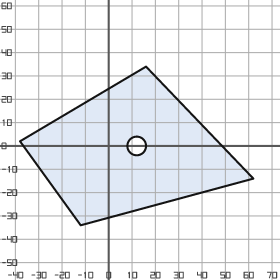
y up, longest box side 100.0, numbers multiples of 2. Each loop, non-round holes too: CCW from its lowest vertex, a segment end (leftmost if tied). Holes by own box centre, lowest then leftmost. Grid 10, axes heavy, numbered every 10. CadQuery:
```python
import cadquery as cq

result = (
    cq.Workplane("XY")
    .moveTo(-12.0, -34.0)
    .lineTo(62.0, -14.0)
    .lineTo(16.0, 34.0)
    .lineTo(-38.0, 2.0)
    .close()
    .moveTo(12.0, 0.0)
    .circle(4.0)
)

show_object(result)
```